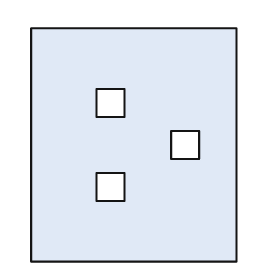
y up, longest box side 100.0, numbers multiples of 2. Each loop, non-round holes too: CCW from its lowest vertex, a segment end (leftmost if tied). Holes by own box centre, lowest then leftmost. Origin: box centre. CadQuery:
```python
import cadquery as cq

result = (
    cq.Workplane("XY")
    .moveTo(-44.0, -50.0)
    .lineTo(44.0, -50.0)
    .lineTo(44.0, 50.0)
    .lineTo(-44.0, 50.0)
    .close()
    .moveTo(-16.0, -24.0)
    .lineTo(-4.0, -24.0)
    .lineTo(-4.0, -12.0)
    .lineTo(-16.0, -12.0)
    .close()
    .moveTo(16.0, -6.0)
    .lineTo(28.0, -6.0)
    .lineTo(28.0, 6.0)
    .lineTo(16.0, 6.0)
    .close()
    .moveTo(-16.0, 12.0)
    .lineTo(-4.0, 12.0)
    .lineTo(-4.0, 24.0)
    .lineTo(-16.0, 24.0)
    .close()
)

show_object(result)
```